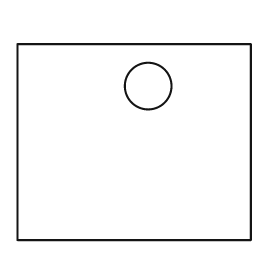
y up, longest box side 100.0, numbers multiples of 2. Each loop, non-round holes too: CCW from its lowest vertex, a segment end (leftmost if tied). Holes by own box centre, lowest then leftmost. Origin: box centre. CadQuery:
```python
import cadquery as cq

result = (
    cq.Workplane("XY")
    .moveTo(-50.0, -42.0)
    .lineTo(50.0, -42.0)
    .lineTo(50.0, 42.0)
    .lineTo(-50.0, 42.0)
    .close()
    .moveTo(6.0, 24.0)
    .circle(10.0)
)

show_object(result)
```